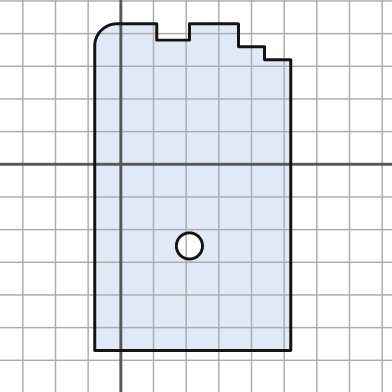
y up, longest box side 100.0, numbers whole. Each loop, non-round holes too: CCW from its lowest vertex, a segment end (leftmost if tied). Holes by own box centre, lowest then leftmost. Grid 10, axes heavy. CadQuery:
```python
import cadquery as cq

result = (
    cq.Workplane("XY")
    .moveTo(-8.0, -57.0)
    .lineTo(52.0, -57.0)
    .lineTo(52.0, 32.0)
    .lineTo(44.0, 32.0)
    .lineTo(44.0, 36.0)
    .lineTo(36.0, 36.0)
    .lineTo(36.0, 43.0)
    .lineTo(21.0, 43.0)
    .lineTo(21.0, 38.0)
    .lineTo(11.0, 38.0)
    .lineTo(11.0, 43.0)
    .lineTo(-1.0, 43.0)
    .threePointArc((-6.0, 41.0), (-8.0, 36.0))
    .close()
    .moveTo(21.0, -25.0)
    .circle(4.0)
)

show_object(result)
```